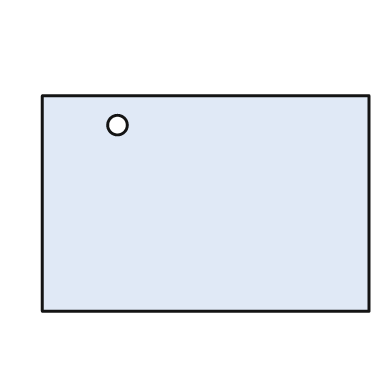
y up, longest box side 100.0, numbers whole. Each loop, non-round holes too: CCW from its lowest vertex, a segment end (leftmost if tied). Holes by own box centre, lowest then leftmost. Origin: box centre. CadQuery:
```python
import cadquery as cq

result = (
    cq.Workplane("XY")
    .moveTo(-50.0, -33.0)
    .lineTo(50.0, -33.0)
    .lineTo(50.0, 33.0)
    .lineTo(-50.0, 33.0)
    .close()
    .moveTo(-27.0, 24.0)
    .circle(3.0)
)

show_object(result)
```